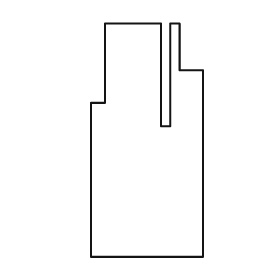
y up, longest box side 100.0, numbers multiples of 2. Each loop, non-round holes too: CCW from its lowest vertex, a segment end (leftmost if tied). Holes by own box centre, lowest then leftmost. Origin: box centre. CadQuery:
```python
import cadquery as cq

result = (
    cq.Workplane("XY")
    .moveTo(-24.0, -50.0)
    .lineTo(24.0, -50.0)
    .lineTo(24.0, 30.0)
    .lineTo(14.0, 30.0)
    .lineTo(14.0, 50.0)
    .lineTo(10.0, 50.0)
    .lineTo(10.0, 6.0)
    .lineTo(6.0, 6.0)
    .lineTo(6.0, 50.0)
    .lineTo(-18.0, 50.0)
    .lineTo(-18.0, 16.0)
    .lineTo(-24.0, 16.0)
    .close()
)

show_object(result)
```